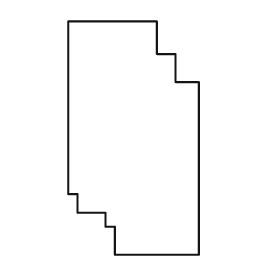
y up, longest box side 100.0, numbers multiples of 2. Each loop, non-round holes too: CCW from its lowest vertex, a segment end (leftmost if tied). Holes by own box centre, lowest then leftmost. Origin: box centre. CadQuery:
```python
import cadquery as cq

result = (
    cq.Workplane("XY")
    .moveTo(-8.0, -50.0)
    .lineTo(28.0, -50.0)
    .lineTo(28.0, 24.0)
    .lineTo(18.0, 24.0)
    .lineTo(18.0, 36.0)
    .lineTo(10.0, 36.0)
    .lineTo(10.0, 50.0)
    .lineTo(-28.0, 50.0)
    .lineTo(-28.0, -24.0)
    .lineTo(-24.0, -24.0)
    .lineTo(-24.0, -32.0)
    .lineTo(-12.0, -32.0)
    .lineTo(-12.0, -38.0)
    .lineTo(-8.0, -38.0)
    .close()
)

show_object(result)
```